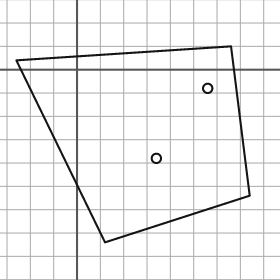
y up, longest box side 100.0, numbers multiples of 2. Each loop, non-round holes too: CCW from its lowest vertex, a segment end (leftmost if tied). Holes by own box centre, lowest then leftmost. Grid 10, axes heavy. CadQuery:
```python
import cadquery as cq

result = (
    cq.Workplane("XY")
    .moveTo(12.0, -74.0)
    .lineTo(74.0, -54.0)
    .lineTo(66.0, 10.0)
    .lineTo(-26.0, 4.0)
    .close()
    .moveTo(34.0, -38.0)
    .circle(2.0)
    .moveTo(56.0, -8.0)
    .circle(2.0)
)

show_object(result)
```